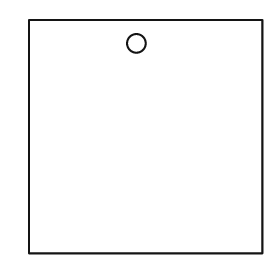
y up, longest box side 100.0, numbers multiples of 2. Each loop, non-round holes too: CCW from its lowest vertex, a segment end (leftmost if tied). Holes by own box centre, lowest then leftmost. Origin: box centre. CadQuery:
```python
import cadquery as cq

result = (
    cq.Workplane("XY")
    .moveTo(-50.0, -50.0)
    .lineTo(50.0, -50.0)
    .lineTo(50.0, 50.0)
    .lineTo(-50.0, 50.0)
    .close()
    .moveTo(-4.0, 40.0)
    .circle(4.0)
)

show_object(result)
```